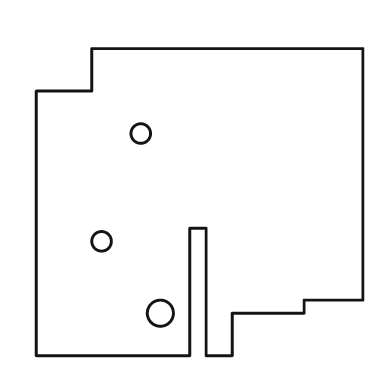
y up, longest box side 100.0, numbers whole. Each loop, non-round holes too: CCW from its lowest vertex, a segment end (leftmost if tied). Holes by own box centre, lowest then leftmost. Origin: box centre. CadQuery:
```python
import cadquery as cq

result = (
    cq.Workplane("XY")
    .moveTo(-50.0, -47.0)
    .lineTo(-3.0, -47.0)
    .lineTo(-3.0, -8.0)
    .lineTo(2.0, -8.0)
    .lineTo(2.0, -47.0)
    .lineTo(10.0, -47.0)
    .lineTo(10.0, -34.0)
    .lineTo(32.0, -34.0)
    .lineTo(32.0, -30.0)
    .lineTo(50.0, -30.0)
    .lineTo(50.0, 47.0)
    .lineTo(-33.0, 47.0)
    .lineTo(-33.0, 34.0)
    .lineTo(-50.0, 34.0)
    .close()
    .moveTo(-12.0, -34.0)
    .circle(4.0)
    .moveTo(-30.0, -12.0)
    .circle(3.0)
    .moveTo(-18.0, 21.0)
    .circle(3.0)
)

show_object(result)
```